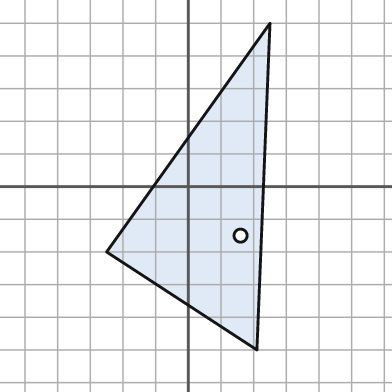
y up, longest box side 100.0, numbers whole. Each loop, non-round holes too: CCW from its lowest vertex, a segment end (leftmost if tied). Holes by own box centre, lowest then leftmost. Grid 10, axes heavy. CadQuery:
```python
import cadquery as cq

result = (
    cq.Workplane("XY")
    .moveTo(21.0, -50.0)
    .lineTo(25.0, 50.0)
    .lineTo(-25.0, -20.0)
    .close()
    .moveTo(16.0, -15.0)
    .circle(2.0)
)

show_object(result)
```